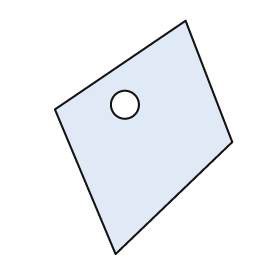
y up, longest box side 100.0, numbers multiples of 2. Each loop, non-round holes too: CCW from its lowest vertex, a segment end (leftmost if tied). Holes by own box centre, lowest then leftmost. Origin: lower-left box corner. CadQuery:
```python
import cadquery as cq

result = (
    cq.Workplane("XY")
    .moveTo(26.0, 0.0)
    .lineTo(76.0, 48.0)
    .lineTo(56.0, 100.0)
    .lineTo(0.0, 62.0)
    .close()
    .moveTo(30.0, 64.0)
    .circle(6.0)
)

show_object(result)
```